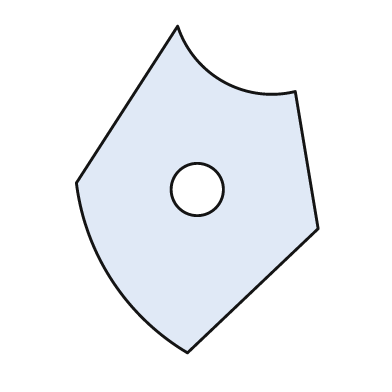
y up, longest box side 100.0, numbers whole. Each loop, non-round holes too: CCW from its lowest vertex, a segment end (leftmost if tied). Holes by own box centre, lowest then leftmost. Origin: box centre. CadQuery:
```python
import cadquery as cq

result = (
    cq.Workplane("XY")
    .moveTo(-3.0, -50.0)
    .lineTo(37.0, -12.0)
    .lineTo(30.0, 30.0)
    .threePointArc((8.0, 33.0), (-6.0, 50.0))
    .lineTo(-37.0, 2.0)
    .threePointArc((-26.0, -28.0), (-3.0, -50.0))
    .close()
    .moveTo(0.0, 0.0)
    .circle(8.0)
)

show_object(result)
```